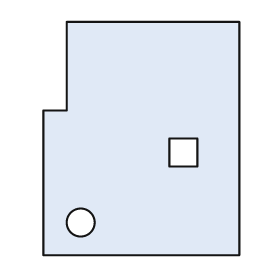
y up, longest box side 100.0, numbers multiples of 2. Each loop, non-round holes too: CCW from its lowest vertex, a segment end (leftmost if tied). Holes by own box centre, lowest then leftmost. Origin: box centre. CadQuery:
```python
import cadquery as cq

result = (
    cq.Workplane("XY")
    .moveTo(-42.0, -50.0)
    .lineTo(42.0, -50.0)
    .lineTo(42.0, 50.0)
    .lineTo(-32.0, 50.0)
    .lineTo(-32.0, 12.0)
    .lineTo(-42.0, 12.0)
    .close()
    .moveTo(-26.0, -36.0)
    .circle(6.0)
    .moveTo(12.0, -12.0)
    .lineTo(24.0, -12.0)
    .lineTo(24.0, 0.0)
    .lineTo(12.0, 0.0)
    .close()
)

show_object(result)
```